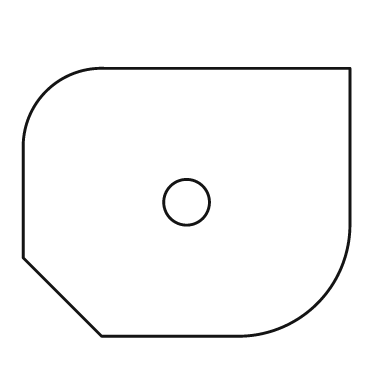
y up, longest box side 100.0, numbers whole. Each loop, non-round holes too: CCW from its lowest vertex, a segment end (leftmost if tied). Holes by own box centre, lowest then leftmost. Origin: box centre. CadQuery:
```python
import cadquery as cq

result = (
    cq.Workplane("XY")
    .moveTo(-26.0, -41.0)
    .lineTo(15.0, -41.0)
    .threePointArc((40.0, -31.0), (50.0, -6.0))
    .lineTo(50.0, 41.0)
    .lineTo(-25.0, 41.0)
    .threePointArc((-43.0, 34.0), (-50.0, 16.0))
    .lineTo(-50.0, -17.0)
    .close()
    .moveTo(0.0, 0.0)
    .circle(7.0)
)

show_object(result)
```